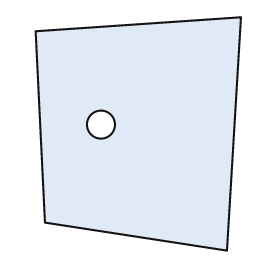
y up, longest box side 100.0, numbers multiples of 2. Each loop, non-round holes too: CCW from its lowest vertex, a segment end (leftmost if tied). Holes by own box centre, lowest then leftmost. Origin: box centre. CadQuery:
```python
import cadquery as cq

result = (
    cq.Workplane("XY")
    .moveTo(38.0, -50.0)
    .lineTo(44.0, 50.0)
    .lineTo(-44.0, 44.0)
    .lineTo(-40.0, -38.0)
    .close()
    .moveTo(-16.0, 4.0)
    .circle(6.0)
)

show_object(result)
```